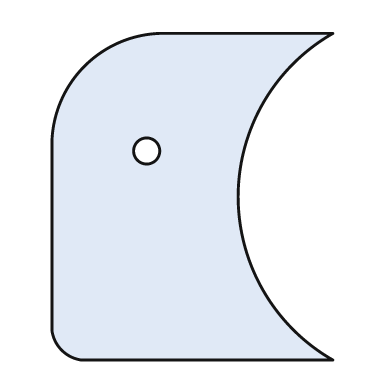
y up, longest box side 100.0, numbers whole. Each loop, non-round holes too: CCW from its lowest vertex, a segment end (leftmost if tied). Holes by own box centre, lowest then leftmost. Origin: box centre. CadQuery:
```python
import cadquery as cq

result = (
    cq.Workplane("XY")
    .moveTo(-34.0, -50.0)
    .lineTo(43.0, -50.0)
    .threePointArc((14.0, 0.0), (43.0, 50.0))
    .lineTo(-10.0, 50.0)
    .threePointArc((-33.0, 40.0), (-43.0, 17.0))
    .lineTo(-43.0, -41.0)
    .threePointArc((-40.0, -47.0), (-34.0, -50.0))
    .close()
    .moveTo(-14.0, 14.0)
    .circle(4.0)
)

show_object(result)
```